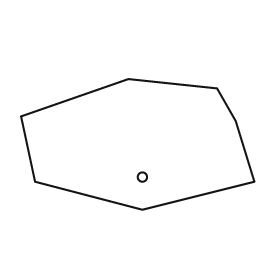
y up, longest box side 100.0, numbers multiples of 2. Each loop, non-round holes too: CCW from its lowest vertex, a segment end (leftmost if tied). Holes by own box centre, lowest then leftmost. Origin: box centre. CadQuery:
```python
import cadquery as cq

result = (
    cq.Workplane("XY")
    .moveTo(2.0, -28.0)
    .lineTo(50.0, -16.0)
    .lineTo(42.0, 10.0)
    .lineTo(34.0, 24.0)
    .lineTo(-4.0, 28.0)
    .lineTo(-50.0, 12.0)
    .lineTo(-44.0, -16.0)
    .close()
    .moveTo(2.0, -14.0)
    .circle(2.0)
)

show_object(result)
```